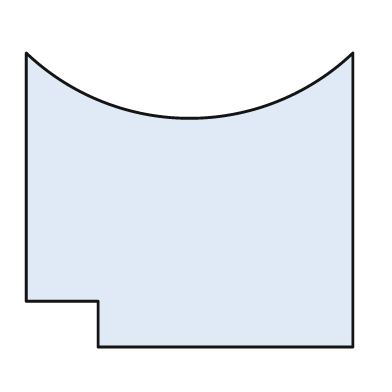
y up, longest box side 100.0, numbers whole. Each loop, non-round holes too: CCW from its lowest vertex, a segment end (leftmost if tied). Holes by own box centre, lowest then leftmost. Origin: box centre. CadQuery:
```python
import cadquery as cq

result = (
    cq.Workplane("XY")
    .moveTo(-28.0, -45.0)
    .lineTo(50.0, -45.0)
    .lineTo(50.0, 45.0)
    .threePointArc((0.0, 25.0), (-50.0, 45.0))
    .lineTo(-50.0, -31.0)
    .lineTo(-28.0, -31.0)
    .close()
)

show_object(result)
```